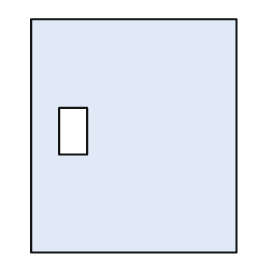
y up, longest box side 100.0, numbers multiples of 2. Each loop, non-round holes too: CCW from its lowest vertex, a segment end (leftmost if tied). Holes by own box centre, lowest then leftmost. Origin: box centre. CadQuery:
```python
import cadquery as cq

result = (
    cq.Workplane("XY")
    .moveTo(-44.0, -50.0)
    .lineTo(44.0, -50.0)
    .lineTo(44.0, 50.0)
    .lineTo(-44.0, 50.0)
    .close()
    .moveTo(-32.0, -8.0)
    .lineTo(-20.0, -8.0)
    .lineTo(-20.0, 12.0)
    .lineTo(-32.0, 12.0)
    .close()
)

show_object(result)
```